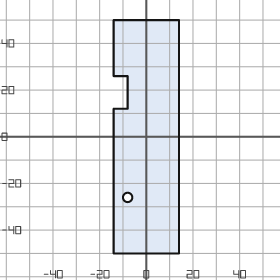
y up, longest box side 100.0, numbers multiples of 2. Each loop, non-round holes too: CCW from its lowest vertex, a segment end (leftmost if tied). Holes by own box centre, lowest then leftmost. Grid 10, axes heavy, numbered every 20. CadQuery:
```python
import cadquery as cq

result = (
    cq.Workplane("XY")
    .moveTo(-14.0, -50.0)
    .lineTo(14.0, -50.0)
    .lineTo(14.0, 50.0)
    .lineTo(-14.0, 50.0)
    .lineTo(-14.0, 26.0)
    .lineTo(-8.0, 26.0)
    .lineTo(-8.0, 12.0)
    .lineTo(-14.0, 12.0)
    .close()
    .moveTo(-8.0, -26.0)
    .circle(2.0)
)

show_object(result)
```